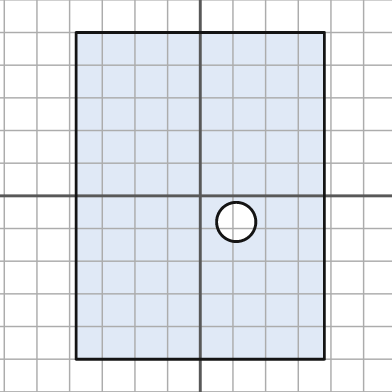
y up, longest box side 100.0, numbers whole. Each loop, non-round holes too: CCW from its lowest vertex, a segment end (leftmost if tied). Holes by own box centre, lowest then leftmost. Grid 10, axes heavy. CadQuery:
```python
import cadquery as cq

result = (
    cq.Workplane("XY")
    .moveTo(-38.0, -50.0)
    .lineTo(38.0, -50.0)
    .lineTo(38.0, 50.0)
    .lineTo(-38.0, 50.0)
    .close()
    .moveTo(11.0, -8.0)
    .circle(6.0)
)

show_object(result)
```